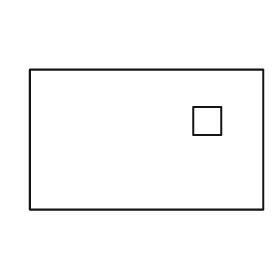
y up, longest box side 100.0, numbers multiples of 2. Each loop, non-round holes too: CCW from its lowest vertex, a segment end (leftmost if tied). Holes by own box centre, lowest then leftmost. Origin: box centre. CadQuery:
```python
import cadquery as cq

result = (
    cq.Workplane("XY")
    .moveTo(-50.0, -30.0)
    .lineTo(50.0, -30.0)
    .lineTo(50.0, 30.0)
    .lineTo(-50.0, 30.0)
    .close()
    .moveTo(20.0, 2.0)
    .lineTo(32.0, 2.0)
    .lineTo(32.0, 14.0)
    .lineTo(20.0, 14.0)
    .close()
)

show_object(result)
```